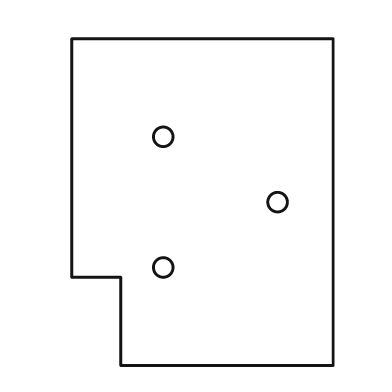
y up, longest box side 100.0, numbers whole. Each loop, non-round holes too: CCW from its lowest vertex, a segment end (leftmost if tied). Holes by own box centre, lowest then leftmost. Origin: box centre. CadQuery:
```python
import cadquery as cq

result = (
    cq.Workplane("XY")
    .moveTo(-25.0, -50.0)
    .lineTo(40.0, -50.0)
    .lineTo(40.0, 50.0)
    .lineTo(-40.0, 50.0)
    .lineTo(-40.0, -23.0)
    .lineTo(-25.0, -23.0)
    .close()
    .moveTo(-12.0, -20.0)
    .circle(3.0)
    .moveTo(23.0, 0.0)
    .circle(3.0)
    .moveTo(-12.0, 20.0)
    .circle(3.0)
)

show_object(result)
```